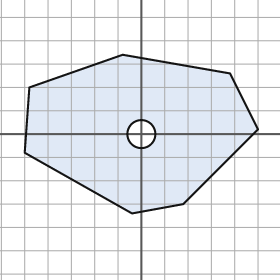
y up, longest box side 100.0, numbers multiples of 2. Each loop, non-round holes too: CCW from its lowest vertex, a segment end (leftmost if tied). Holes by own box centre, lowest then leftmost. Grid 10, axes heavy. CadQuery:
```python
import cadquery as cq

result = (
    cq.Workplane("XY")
    .moveTo(-4.0, -34.0)
    .lineTo(18.0, -30.0)
    .lineTo(50.0, 2.0)
    .lineTo(38.0, 26.0)
    .lineTo(-8.0, 34.0)
    .lineTo(-48.0, 20.0)
    .lineTo(-50.0, -8.0)
    .close()
    .moveTo(0.0, 0.0)
    .circle(6.0)
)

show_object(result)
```